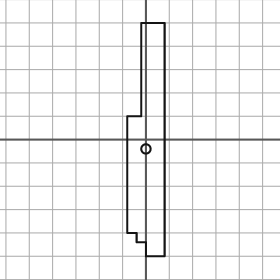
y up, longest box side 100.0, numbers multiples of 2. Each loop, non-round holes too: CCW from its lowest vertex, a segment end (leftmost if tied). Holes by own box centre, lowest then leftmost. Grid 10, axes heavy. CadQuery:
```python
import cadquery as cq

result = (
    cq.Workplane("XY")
    .moveTo(0.0, -50.0)
    .lineTo(8.0, -50.0)
    .lineTo(8.0, 50.0)
    .lineTo(-2.0, 50.0)
    .lineTo(-2.0, 10.0)
    .lineTo(-8.0, 10.0)
    .lineTo(-8.0, -40.0)
    .lineTo(-4.0, -40.0)
    .lineTo(-4.0, -44.0)
    .lineTo(0.0, -44.0)
    .close()
    .moveTo(0.0, -4.0)
    .circle(2.0)
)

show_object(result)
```